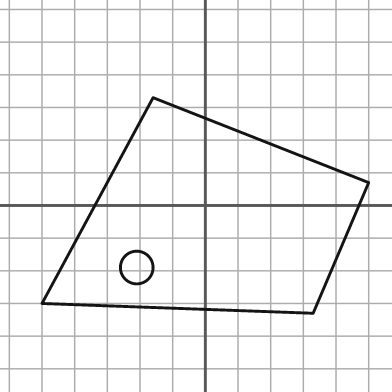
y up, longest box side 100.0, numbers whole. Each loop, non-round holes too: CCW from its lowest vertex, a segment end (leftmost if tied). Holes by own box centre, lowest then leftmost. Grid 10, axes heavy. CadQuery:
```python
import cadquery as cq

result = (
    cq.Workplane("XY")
    .moveTo(33.0, -33.0)
    .lineTo(50.0, 7.0)
    .lineTo(-16.0, 33.0)
    .lineTo(-50.0, -30.0)
    .close()
    .moveTo(-21.0, -19.0)
    .circle(5.0)
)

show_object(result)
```